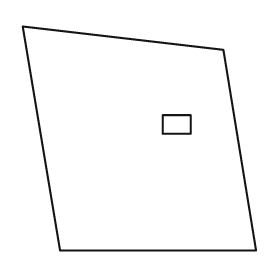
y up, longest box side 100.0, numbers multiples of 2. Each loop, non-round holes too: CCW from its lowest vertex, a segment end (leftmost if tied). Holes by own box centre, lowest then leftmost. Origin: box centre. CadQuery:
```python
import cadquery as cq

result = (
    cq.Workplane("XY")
    .moveTo(-34.0, -48.0)
    .lineTo(50.0, -48.0)
    .lineTo(36.0, 38.0)
    .lineTo(-50.0, 48.0)
    .close()
    .moveTo(10.0, 2.0)
    .lineTo(22.0, 2.0)
    .lineTo(22.0, 10.0)
    .lineTo(10.0, 10.0)
    .close()
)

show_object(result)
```